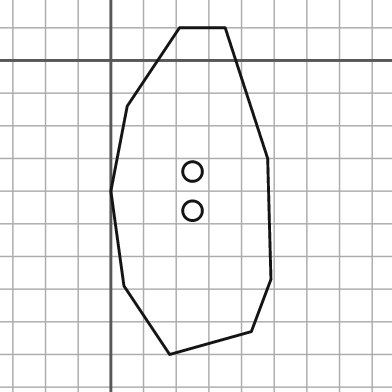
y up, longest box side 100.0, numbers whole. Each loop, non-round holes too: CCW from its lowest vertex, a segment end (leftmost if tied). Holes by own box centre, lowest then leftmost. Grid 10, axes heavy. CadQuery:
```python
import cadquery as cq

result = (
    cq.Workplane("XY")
    .moveTo(18.0, -90.0)
    .lineTo(43.0, -83.0)
    .lineTo(49.0, -67.0)
    .lineTo(48.0, -30.0)
    .lineTo(35.0, 10.0)
    .lineTo(21.0, 10.0)
    .lineTo(5.0, -14.0)
    .lineTo(0.0, -40.0)
    .lineTo(4.0, -69.0)
    .close()
    .moveTo(25.0, -46.0)
    .circle(3.0)
    .moveTo(25.0, -34.0)
    .circle(3.0)
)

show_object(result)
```